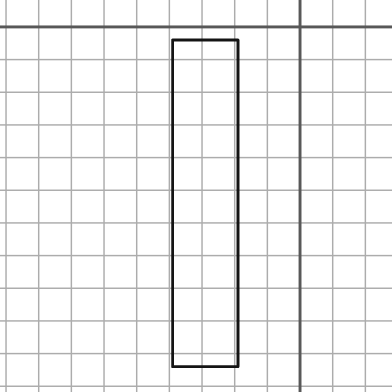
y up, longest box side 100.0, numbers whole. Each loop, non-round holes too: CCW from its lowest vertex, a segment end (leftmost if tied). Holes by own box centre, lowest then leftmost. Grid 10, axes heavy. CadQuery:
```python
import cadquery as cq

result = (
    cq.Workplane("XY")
    .moveTo(-39.0, -104.0)
    .lineTo(-19.0, -104.0)
    .lineTo(-19.0, -4.0)
    .lineTo(-39.0, -4.0)
    .close()
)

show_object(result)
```